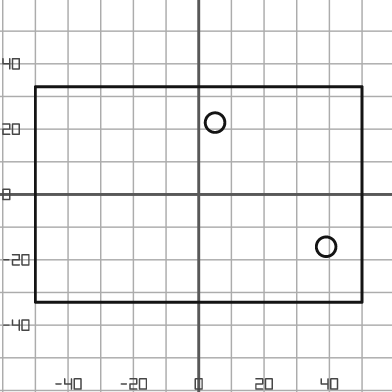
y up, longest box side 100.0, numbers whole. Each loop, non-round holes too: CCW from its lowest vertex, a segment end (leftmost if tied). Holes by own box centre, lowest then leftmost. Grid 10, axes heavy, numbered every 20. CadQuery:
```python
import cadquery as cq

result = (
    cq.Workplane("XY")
    .moveTo(-50.0, -33.0)
    .lineTo(50.0, -33.0)
    .lineTo(50.0, 33.0)
    .lineTo(-50.0, 33.0)
    .close()
    .moveTo(39.0, -16.0)
    .circle(3.0)
    .moveTo(5.0, 22.0)
    .circle(3.0)
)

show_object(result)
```